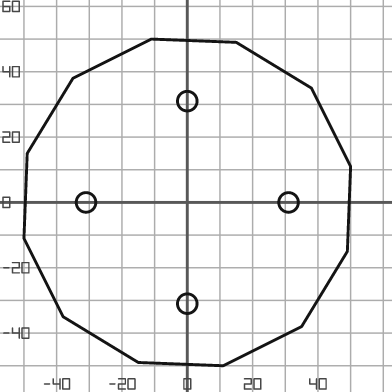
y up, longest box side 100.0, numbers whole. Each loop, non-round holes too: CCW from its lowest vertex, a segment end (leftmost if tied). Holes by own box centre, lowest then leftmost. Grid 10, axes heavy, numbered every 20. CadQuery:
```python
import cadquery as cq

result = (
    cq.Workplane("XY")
    .moveTo(11.0, -50.0)
    .lineTo(35.0, -38.0)
    .lineTo(49.0, -15.0)
    .lineTo(50.0, 11.0)
    .lineTo(38.0, 35.0)
    .lineTo(15.0, 49.0)
    .lineTo(-11.0, 50.0)
    .lineTo(-35.0, 38.0)
    .lineTo(-49.0, 15.0)
    .lineTo(-50.0, -11.0)
    .lineTo(-38.0, -35.0)
    .lineTo(-15.0, -49.0)
    .close()
    .moveTo(0.0, -31.0)
    .circle(3.0)
    .moveTo(-31.0, 0.0)
    .circle(3.0)
    .moveTo(31.0, 0.0)
    .circle(3.0)
    .moveTo(0.0, 31.0)
    .circle(3.0)
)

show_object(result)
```